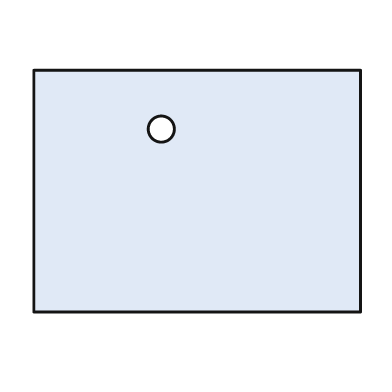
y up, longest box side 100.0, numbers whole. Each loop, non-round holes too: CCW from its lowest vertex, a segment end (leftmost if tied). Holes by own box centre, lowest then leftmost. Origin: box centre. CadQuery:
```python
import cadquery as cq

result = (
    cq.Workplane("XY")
    .moveTo(-50.0, -37.0)
    .lineTo(50.0, -37.0)
    .lineTo(50.0, 37.0)
    .lineTo(-50.0, 37.0)
    .close()
    .moveTo(-11.0, 19.0)
    .circle(4.0)
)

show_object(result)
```